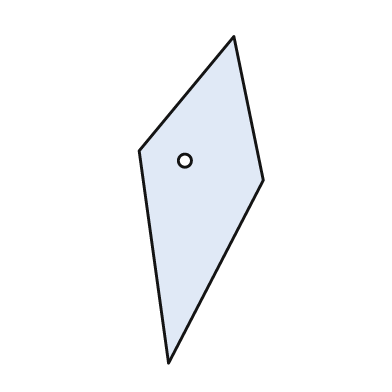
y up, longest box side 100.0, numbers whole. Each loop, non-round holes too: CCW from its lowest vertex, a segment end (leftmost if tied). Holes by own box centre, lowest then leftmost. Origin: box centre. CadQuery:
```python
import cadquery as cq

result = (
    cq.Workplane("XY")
    .moveTo(-10.0, -50.0)
    .lineTo(19.0, 6.0)
    .lineTo(10.0, 50.0)
    .lineTo(-19.0, 15.0)
    .close()
    .moveTo(-5.0, 12.0)
    .circle(2.0)
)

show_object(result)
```